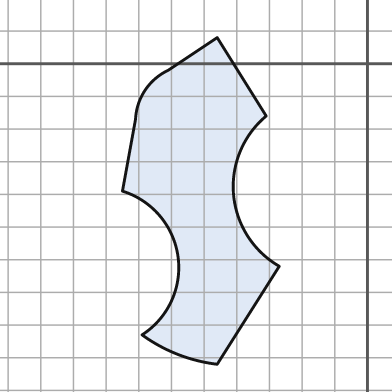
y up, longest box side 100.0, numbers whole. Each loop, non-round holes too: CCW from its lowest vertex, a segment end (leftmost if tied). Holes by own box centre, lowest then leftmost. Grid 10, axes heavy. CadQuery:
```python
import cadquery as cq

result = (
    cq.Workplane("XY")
    .moveTo(-46.0, -92.0)
    .lineTo(-27.0, -62.0)
    .threePointArc((-41.0, -40.0), (-31.0, -16.0))
    .lineTo(-46.0, 8.0)
    .lineTo(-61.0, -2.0)
    .threePointArc((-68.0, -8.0), (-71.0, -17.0))
    .lineTo(-75.0, -39.0)
    .threePointArc((-58.0, -59.0), (-69.0, -83.0))
    .threePointArc((-58.0, -89.0), (-46.0, -92.0))
    .close()
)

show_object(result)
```